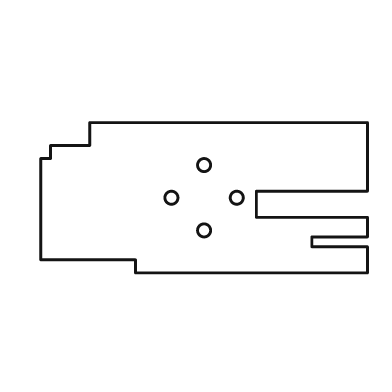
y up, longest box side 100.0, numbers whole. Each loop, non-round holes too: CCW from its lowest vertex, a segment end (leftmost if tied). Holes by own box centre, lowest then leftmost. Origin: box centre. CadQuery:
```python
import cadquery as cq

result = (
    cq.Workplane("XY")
    .moveTo(-21.0, -23.0)
    .lineTo(50.0, -23.0)
    .lineTo(50.0, -15.0)
    .lineTo(33.0, -15.0)
    .lineTo(33.0, -12.0)
    .lineTo(50.0, -12.0)
    .lineTo(50.0, -6.0)
    .lineTo(16.0, -6.0)
    .lineTo(16.0, 2.0)
    .lineTo(50.0, 2.0)
    .lineTo(50.0, 23.0)
    .lineTo(-35.0, 23.0)
    .lineTo(-35.0, 16.0)
    .lineTo(-47.0, 16.0)
    .lineTo(-47.0, 12.0)
    .lineTo(-50.0, 12.0)
    .lineTo(-50.0, -19.0)
    .lineTo(-21.0, -19.0)
    .close()
    .moveTo(0.0, -10.0)
    .circle(2.0)
    .moveTo(-10.0, 0.0)
    .circle(2.0)
    .moveTo(10.0, 0.0)
    .circle(2.0)
    .moveTo(0.0, 10.0)
    .circle(2.0)
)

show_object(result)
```